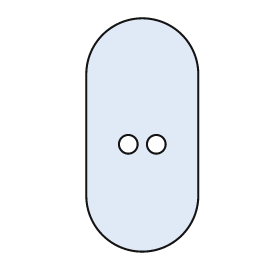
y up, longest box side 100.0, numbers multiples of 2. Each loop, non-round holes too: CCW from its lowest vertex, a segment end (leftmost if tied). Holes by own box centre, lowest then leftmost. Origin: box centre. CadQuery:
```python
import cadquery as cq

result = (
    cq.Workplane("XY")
    .moveTo(-24.0, -26.0)
    .threePointArc((0.0, -50.0), (24.0, -26.0))
    .lineTo(24.0, 26.0)
    .threePointArc((0.0, 50.0), (-24.0, 26.0))
    .close()
    .moveTo(-6.0, -4.0)
    .circle(4.0)
    .moveTo(6.0, -4.0)
    .circle(4.0)
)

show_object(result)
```